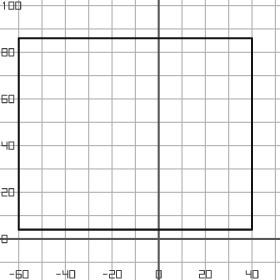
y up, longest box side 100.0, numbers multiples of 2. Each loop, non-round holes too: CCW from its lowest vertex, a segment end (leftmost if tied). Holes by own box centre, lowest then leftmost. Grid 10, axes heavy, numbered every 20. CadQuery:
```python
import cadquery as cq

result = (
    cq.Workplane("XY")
    .moveTo(-60.0, 4.0)
    .lineTo(40.0, 4.0)
    .lineTo(40.0, 86.0)
    .lineTo(-60.0, 86.0)
    .close()
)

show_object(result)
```